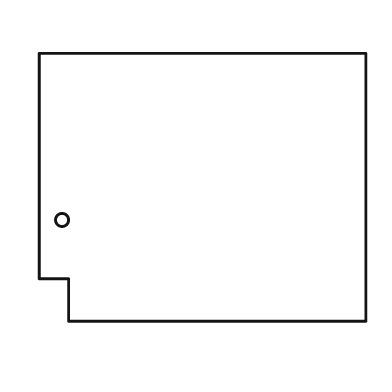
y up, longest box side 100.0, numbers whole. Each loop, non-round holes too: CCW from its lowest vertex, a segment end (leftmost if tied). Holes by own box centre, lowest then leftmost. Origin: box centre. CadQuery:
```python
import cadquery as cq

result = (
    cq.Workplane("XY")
    .moveTo(-41.0, -41.0)
    .lineTo(50.0, -41.0)
    .lineTo(50.0, 41.0)
    .lineTo(-50.0, 41.0)
    .lineTo(-50.0, -28.0)
    .lineTo(-41.0, -28.0)
    .close()
    .moveTo(-43.0, -10.0)
    .circle(2.0)
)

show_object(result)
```